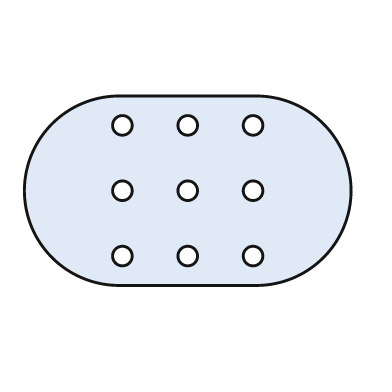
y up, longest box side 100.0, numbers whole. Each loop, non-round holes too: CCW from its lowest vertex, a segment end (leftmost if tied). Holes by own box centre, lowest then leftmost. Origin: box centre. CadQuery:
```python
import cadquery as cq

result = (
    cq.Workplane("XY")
    .moveTo(-21.0, -29.0)
    .lineTo(21.0, -29.0)
    .threePointArc((50.0, 0.0), (21.0, 29.0))
    .lineTo(-21.0, 29.0)
    .threePointArc((-50.0, 0.0), (-21.0, -29.0))
    .close()
    .moveTo(-20.0, -20.0)
    .circle(3.0)
    .moveTo(0.0, -20.0)
    .circle(3.0)
    .moveTo(20.0, -20.0)
    .circle(3.0)
    .moveTo(-20.0, 0.0)
    .circle(3.0)
    .moveTo(0.0, 0.0)
    .circle(3.0)
    .moveTo(20.0, 0.0)
    .circle(3.0)
    .moveTo(-20.0, 20.0)
    .circle(3.0)
    .moveTo(0.0, 20.0)
    .circle(3.0)
    .moveTo(20.0, 20.0)
    .circle(3.0)
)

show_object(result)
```